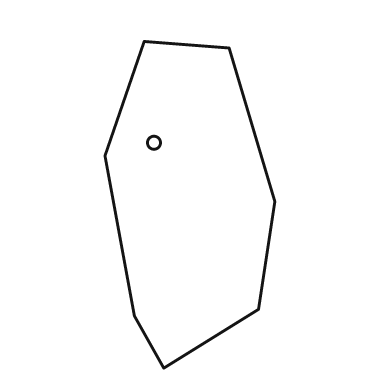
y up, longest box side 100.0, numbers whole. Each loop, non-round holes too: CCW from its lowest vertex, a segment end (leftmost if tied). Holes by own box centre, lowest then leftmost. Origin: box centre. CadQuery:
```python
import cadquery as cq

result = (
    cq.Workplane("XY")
    .moveTo(-8.0, -50.0)
    .lineTo(21.0, -32.0)
    .lineTo(26.0, 1.0)
    .lineTo(12.0, 48.0)
    .lineTo(-14.0, 50.0)
    .lineTo(-26.0, 15.0)
    .lineTo(-17.0, -34.0)
    .close()
    .moveTo(-11.0, 19.0)
    .circle(2.0)
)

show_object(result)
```